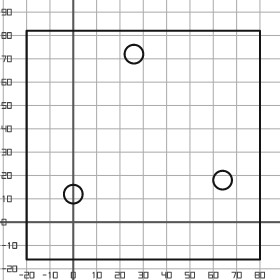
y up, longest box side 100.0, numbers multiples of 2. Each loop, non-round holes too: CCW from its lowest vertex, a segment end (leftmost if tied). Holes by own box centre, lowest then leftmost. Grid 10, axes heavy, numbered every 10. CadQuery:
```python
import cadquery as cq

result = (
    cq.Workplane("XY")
    .moveTo(-20.0, -16.0)
    .lineTo(80.0, -16.0)
    .lineTo(80.0, 82.0)
    .lineTo(-20.0, 82.0)
    .close()
    .moveTo(0.0, 12.0)
    .circle(4.0)
    .moveTo(64.0, 18.0)
    .circle(4.0)
    .moveTo(26.0, 72.0)
    .circle(4.0)
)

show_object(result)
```